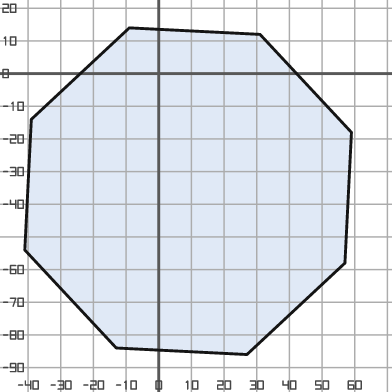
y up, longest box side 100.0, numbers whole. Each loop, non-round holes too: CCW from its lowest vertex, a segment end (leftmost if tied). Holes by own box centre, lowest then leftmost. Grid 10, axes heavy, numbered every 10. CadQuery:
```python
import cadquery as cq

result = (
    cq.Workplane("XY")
    .moveTo(27.0, -86.0)
    .lineTo(57.0, -58.0)
    .lineTo(59.0, -18.0)
    .lineTo(31.0, 12.0)
    .lineTo(-9.0, 14.0)
    .lineTo(-39.0, -14.0)
    .lineTo(-41.0, -54.0)
    .lineTo(-13.0, -84.0)
    .close()
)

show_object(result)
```